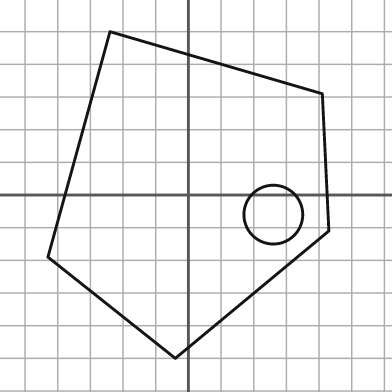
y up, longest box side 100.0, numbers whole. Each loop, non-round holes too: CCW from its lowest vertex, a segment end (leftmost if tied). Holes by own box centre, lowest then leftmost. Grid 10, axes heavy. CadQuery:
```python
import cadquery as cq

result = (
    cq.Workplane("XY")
    .moveTo(-4.0, -50.0)
    .lineTo(43.0, -11.0)
    .lineTo(41.0, 31.0)
    .lineTo(-24.0, 50.0)
    .lineTo(-43.0, -19.0)
    .close()
    .moveTo(26.0, -6.0)
    .circle(9.0)
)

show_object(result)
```